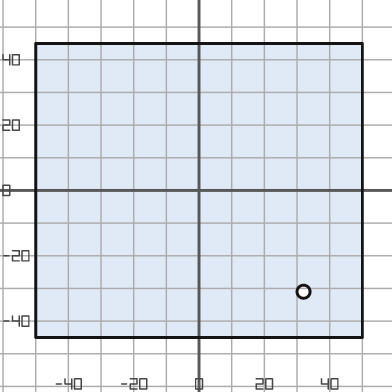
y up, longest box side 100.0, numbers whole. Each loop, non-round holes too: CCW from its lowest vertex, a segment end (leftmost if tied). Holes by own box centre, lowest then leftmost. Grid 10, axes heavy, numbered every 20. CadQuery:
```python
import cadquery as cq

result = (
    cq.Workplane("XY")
    .moveTo(-50.0, -45.0)
    .lineTo(50.0, -45.0)
    .lineTo(50.0, 45.0)
    .lineTo(-50.0, 45.0)
    .close()
    .moveTo(32.0, -31.0)
    .circle(2.0)
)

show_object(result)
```